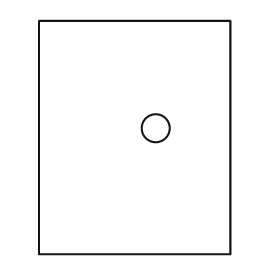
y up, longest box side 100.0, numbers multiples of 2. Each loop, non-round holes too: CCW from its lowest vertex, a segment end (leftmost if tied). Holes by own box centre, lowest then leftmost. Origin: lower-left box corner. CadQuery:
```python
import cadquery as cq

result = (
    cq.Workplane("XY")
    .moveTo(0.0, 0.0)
    .lineTo(82.0, 0.0)
    .lineTo(82.0, 100.0)
    .lineTo(0.0, 100.0)
    .close()
    .moveTo(50.0, 54.0)
    .circle(6.0)
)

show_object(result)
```